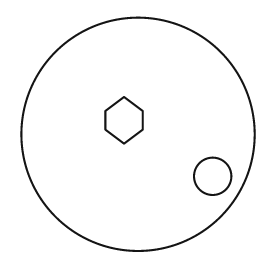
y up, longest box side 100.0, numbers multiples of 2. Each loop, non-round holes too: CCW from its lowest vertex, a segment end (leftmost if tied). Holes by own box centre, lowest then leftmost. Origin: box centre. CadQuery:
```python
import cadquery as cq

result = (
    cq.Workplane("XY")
    .moveTo(0.0, 0.0)
    .circle(50.0)
    .moveTo(32.0, -18.0)
    .circle(8.0)
    .moveTo(-6.0, -4.0)
    .lineTo(2.0, 2.0)
    .lineTo(2.0, 10.0)
    .lineTo(-6.0, 16.0)
    .lineTo(-14.0, 10.0)
    .lineTo(-14.0, 2.0)
    .close()
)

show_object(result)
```